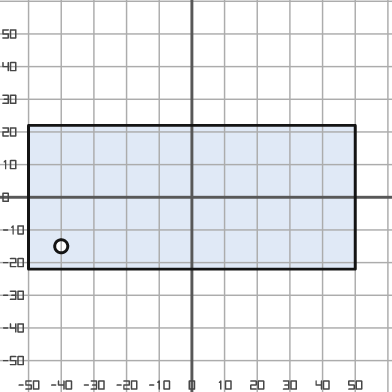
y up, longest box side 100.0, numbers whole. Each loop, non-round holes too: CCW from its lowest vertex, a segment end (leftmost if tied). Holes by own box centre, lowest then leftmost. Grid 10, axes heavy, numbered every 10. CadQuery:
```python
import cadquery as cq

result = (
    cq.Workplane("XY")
    .moveTo(-50.0, -22.0)
    .lineTo(50.0, -22.0)
    .lineTo(50.0, 22.0)
    .lineTo(-50.0, 22.0)
    .close()
    .moveTo(-40.0, -15.0)
    .circle(2.0)
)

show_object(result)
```